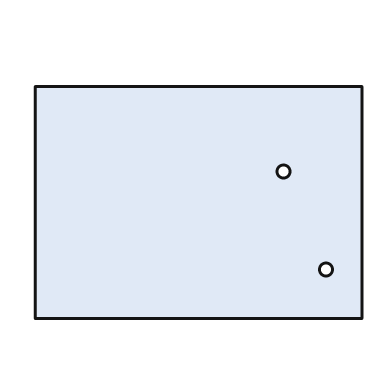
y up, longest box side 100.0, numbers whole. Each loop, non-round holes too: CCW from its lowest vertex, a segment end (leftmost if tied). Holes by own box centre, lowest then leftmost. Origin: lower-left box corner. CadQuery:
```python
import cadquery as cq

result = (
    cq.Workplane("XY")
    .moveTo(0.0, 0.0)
    .lineTo(100.0, 0.0)
    .lineTo(100.0, 71.0)
    .lineTo(0.0, 71.0)
    .close()
    .moveTo(89.0, 15.0)
    .circle(2.0)
    .moveTo(76.0, 45.0)
    .circle(2.0)
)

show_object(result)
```